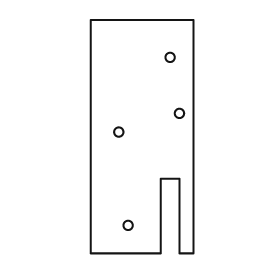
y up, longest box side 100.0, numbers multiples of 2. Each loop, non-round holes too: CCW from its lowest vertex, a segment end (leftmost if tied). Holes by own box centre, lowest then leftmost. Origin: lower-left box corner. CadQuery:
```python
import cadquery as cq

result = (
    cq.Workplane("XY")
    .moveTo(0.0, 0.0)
    .lineTo(30.0, 0.0)
    .lineTo(30.0, 32.0)
    .lineTo(38.0, 32.0)
    .lineTo(38.0, 0.0)
    .lineTo(44.0, 0.0)
    .lineTo(44.0, 100.0)
    .lineTo(0.0, 100.0)
    .close()
    .moveTo(16.0, 12.0)
    .circle(2.0)
    .moveTo(12.0, 52.0)
    .circle(2.0)
    .moveTo(38.0, 60.0)
    .circle(2.0)
    .moveTo(34.0, 84.0)
    .circle(2.0)
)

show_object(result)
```